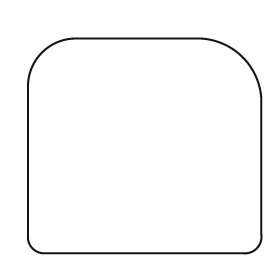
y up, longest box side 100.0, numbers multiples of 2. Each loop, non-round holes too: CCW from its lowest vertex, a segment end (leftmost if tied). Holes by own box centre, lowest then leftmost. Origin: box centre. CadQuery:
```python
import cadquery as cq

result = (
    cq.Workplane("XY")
    .moveTo(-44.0, -46.0)
    .lineTo(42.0, -46.0)
    .threePointArc((48.0, -44.0), (50.0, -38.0))
    .lineTo(50.0, 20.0)
    .threePointArc((42.0, 38.0), (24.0, 46.0))
    .lineTo(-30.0, 46.0)
    .threePointArc((-44.0, 40.0), (-50.0, 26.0))
    .lineTo(-50.0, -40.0)
    .threePointArc((-48.0, -44.0), (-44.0, -46.0))
    .close()
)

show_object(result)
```